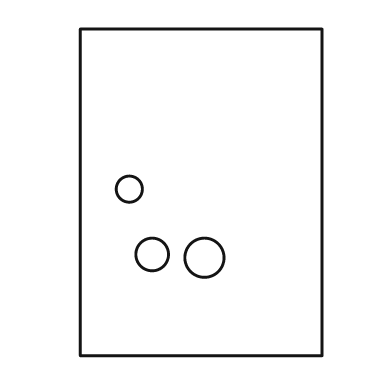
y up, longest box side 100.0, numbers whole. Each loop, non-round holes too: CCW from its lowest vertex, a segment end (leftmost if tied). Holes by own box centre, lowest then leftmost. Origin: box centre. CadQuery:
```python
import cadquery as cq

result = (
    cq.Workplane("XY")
    .moveTo(-37.0, -50.0)
    .lineTo(37.0, -50.0)
    .lineTo(37.0, 50.0)
    .lineTo(-37.0, 50.0)
    .close()
    .moveTo(1.0, -20.0)
    .circle(6.0)
    .moveTo(-15.0, -19.0)
    .circle(5.0)
    .moveTo(-22.0, 1.0)
    .circle(4.0)
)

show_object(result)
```